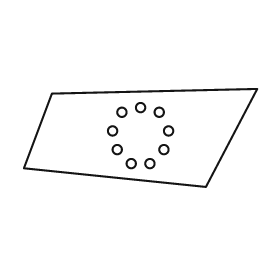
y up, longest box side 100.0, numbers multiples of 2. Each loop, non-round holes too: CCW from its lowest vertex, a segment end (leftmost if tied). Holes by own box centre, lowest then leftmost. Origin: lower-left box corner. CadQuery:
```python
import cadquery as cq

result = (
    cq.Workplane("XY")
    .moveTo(78.0, 0.0)
    .lineTo(100.0, 42.0)
    .lineTo(12.0, 40.0)
    .lineTo(0.0, 8.0)
    .close()
    .moveTo(46.0, 10.0)
    .circle(2.0)
    .moveTo(54.0, 10.0)
    .circle(2.0)
    .moveTo(40.0, 16.0)
    .circle(2.0)
    .moveTo(60.0, 16.0)
    .circle(2.0)
    .moveTo(38.0, 24.0)
    .circle(2.0)
    .moveTo(62.0, 24.0)
    .circle(2.0)
    .moveTo(42.0, 32.0)
    .circle(2.0)
    .moveTo(58.0, 32.0)
    .circle(2.0)
    .moveTo(50.0, 34.0)
    .circle(2.0)
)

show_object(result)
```